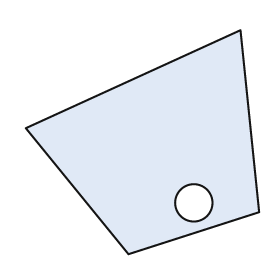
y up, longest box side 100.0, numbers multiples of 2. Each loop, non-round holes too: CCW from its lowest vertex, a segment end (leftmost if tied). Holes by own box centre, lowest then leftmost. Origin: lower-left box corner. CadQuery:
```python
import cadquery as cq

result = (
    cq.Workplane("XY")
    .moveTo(44.0, 0.0)
    .lineTo(100.0, 18.0)
    .lineTo(92.0, 96.0)
    .lineTo(0.0, 54.0)
    .close()
    .moveTo(72.0, 22.0)
    .circle(8.0)
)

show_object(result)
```